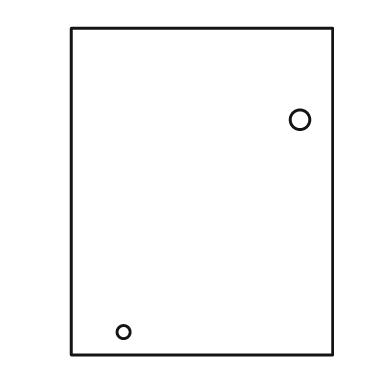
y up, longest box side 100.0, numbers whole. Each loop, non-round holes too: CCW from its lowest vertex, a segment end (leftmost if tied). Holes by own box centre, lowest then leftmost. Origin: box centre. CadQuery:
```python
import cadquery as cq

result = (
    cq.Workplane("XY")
    .moveTo(-40.0, -50.0)
    .lineTo(40.0, -50.0)
    .lineTo(40.0, 50.0)
    .lineTo(-40.0, 50.0)
    .close()
    .moveTo(-24.0, -43.0)
    .circle(2.0)
    .moveTo(30.0, 22.0)
    .circle(3.0)
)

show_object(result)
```